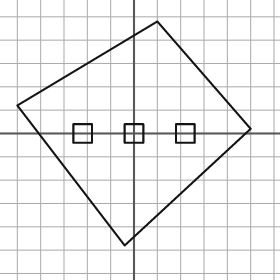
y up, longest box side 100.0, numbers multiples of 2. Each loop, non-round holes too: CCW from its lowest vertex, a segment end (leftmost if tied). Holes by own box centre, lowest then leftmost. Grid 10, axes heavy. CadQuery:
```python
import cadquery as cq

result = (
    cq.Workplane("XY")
    .moveTo(-4.0, -48.0)
    .lineTo(50.0, 2.0)
    .lineTo(10.0, 48.0)
    .lineTo(-50.0, 12.0)
    .close()
    .moveTo(-26.0, -4.0)
    .lineTo(-18.0, -4.0)
    .lineTo(-18.0, 4.0)
    .lineTo(-26.0, 4.0)
    .close()
    .moveTo(-4.0, -4.0)
    .lineTo(4.0, -4.0)
    .lineTo(4.0, 4.0)
    .lineTo(-4.0, 4.0)
    .close()
    .moveTo(18.0, -4.0)
    .lineTo(26.0, -4.0)
    .lineTo(26.0, 4.0)
    .lineTo(18.0, 4.0)
    .close()
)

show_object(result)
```